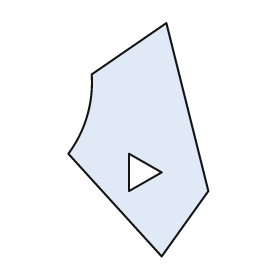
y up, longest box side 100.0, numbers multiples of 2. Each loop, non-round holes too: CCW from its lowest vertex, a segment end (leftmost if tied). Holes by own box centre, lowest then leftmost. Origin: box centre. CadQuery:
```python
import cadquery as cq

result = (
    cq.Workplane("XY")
    .moveTo(10.0, -50.0)
    .lineTo(30.0, -22.0)
    .lineTo(12.0, 50.0)
    .lineTo(-20.0, 28.0)
    .threePointArc((-22.0, 10.0), (-30.0, -6.0))
    .close()
    .moveTo(-4.0, -22.0)
    .lineTo(10.0, -14.0)
    .lineTo(-4.0, -6.0)
    .close()
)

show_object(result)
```